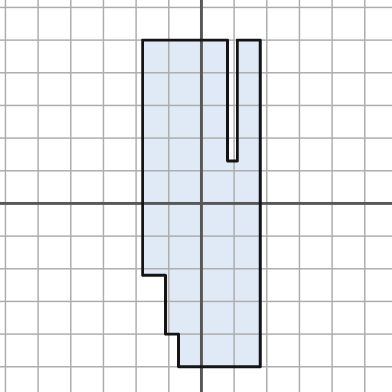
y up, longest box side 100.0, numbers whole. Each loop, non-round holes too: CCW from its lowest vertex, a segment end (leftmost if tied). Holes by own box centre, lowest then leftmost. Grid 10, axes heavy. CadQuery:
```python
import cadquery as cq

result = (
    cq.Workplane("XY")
    .moveTo(-7.0, -50.0)
    .lineTo(18.0, -50.0)
    .lineTo(18.0, 50.0)
    .lineTo(11.0, 50.0)
    .lineTo(11.0, 13.0)
    .lineTo(8.0, 13.0)
    .lineTo(8.0, 50.0)
    .lineTo(-18.0, 50.0)
    .lineTo(-18.0, -22.0)
    .lineTo(-11.0, -22.0)
    .lineTo(-11.0, -40.0)
    .lineTo(-7.0, -40.0)
    .close()
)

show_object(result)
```